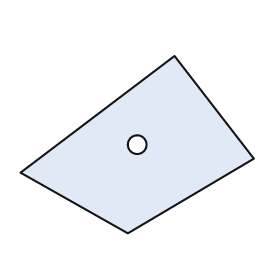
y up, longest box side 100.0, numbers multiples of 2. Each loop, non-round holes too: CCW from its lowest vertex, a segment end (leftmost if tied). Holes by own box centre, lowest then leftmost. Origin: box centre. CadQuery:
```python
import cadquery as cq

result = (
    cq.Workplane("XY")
    .moveTo(-4.0, -38.0)
    .lineTo(50.0, -6.0)
    .lineTo(16.0, 38.0)
    .lineTo(-50.0, -12.0)
    .close()
    .moveTo(0.0, 0.0)
    .circle(4.0)
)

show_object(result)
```